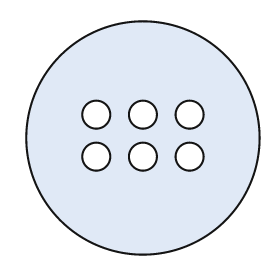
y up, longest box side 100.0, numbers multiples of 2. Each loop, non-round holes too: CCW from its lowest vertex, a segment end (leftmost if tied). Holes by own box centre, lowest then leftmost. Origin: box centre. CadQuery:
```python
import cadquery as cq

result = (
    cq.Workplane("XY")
    .moveTo(0.0, 0.0)
    .circle(50.0)
    .moveTo(-20.0, -8.0)
    .circle(6.0)
    .moveTo(0.0, -8.0)
    .circle(6.0)
    .moveTo(20.0, -8.0)
    .circle(6.0)
    .moveTo(-20.0, 10.0)
    .circle(6.0)
    .moveTo(0.0, 10.0)
    .circle(6.0)
    .moveTo(20.0, 10.0)
    .circle(6.0)
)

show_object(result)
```